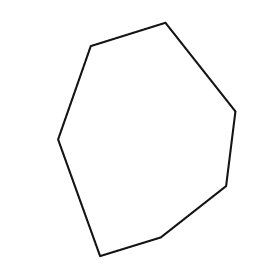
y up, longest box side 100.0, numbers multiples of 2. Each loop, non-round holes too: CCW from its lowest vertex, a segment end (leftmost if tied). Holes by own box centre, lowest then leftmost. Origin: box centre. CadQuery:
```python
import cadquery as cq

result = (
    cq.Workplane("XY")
    .moveTo(-20.0, -50.0)
    .lineTo(6.0, -42.0)
    .lineTo(34.0, -20.0)
    .lineTo(38.0, 12.0)
    .lineTo(8.0, 50.0)
    .lineTo(-24.0, 40.0)
    .lineTo(-38.0, 0.0)
    .close()
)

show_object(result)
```